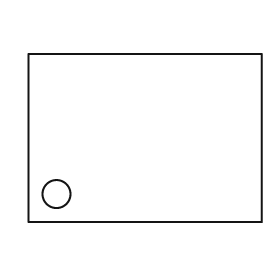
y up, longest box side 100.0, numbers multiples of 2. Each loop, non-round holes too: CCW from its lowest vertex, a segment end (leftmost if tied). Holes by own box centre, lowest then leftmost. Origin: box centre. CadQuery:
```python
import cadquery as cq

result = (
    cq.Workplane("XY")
    .moveTo(-50.0, -36.0)
    .lineTo(50.0, -36.0)
    .lineTo(50.0, 36.0)
    .lineTo(-50.0, 36.0)
    .close()
    .moveTo(-38.0, -24.0)
    .circle(6.0)
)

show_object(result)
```